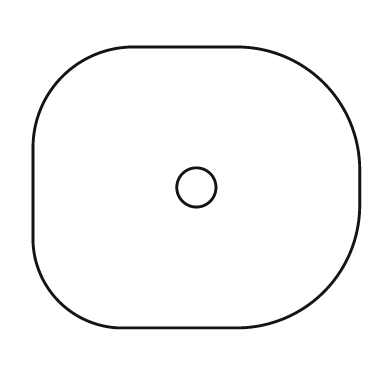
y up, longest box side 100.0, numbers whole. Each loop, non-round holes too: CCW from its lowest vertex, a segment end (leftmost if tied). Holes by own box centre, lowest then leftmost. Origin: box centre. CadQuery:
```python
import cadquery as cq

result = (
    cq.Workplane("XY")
    .moveTo(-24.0, -43.0)
    .lineTo(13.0, -43.0)
    .threePointArc((39.0, -32.0), (50.0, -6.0))
    .lineTo(50.0, 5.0)
    .threePointArc((39.0, 32.0), (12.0, 43.0))
    .lineTo(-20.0, 43.0)
    .threePointArc((-41.0, 34.0), (-50.0, 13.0))
    .lineTo(-50.0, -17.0)
    .threePointArc((-42.0, -35.0), (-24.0, -43.0))
    .close()
    .moveTo(0.0, 0.0)
    .circle(6.0)
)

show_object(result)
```